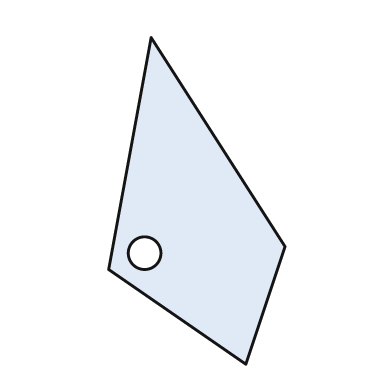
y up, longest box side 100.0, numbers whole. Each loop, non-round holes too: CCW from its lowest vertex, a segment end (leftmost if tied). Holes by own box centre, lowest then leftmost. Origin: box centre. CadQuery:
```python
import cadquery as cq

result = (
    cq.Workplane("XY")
    .moveTo(15.0, -50.0)
    .lineTo(27.0, -14.0)
    .lineTo(-14.0, 50.0)
    .lineTo(-27.0, -21.0)
    .close()
    .moveTo(-16.0, -16.0)
    .circle(5.0)
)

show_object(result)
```